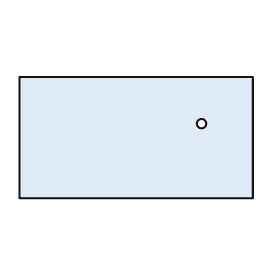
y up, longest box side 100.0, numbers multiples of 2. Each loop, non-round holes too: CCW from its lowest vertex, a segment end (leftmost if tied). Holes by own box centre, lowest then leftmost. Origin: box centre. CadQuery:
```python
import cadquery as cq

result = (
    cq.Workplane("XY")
    .moveTo(-50.0, -26.0)
    .lineTo(50.0, -26.0)
    .lineTo(50.0, 26.0)
    .lineTo(-50.0, 26.0)
    .close()
    .moveTo(28.0, 6.0)
    .circle(2.0)
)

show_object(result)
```